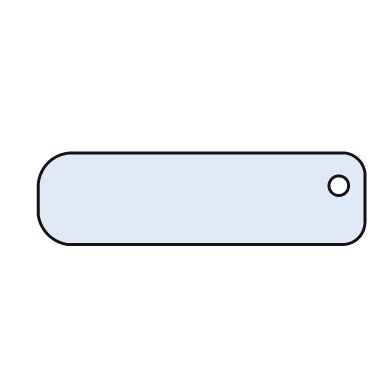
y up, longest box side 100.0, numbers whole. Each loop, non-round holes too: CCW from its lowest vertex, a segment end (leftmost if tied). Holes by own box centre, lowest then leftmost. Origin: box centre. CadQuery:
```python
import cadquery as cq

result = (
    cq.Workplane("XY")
    .moveTo(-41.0, -14.0)
    .lineTo(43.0, -14.0)
    .threePointArc((48.0, -12.0), (50.0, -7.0))
    .lineTo(50.0, 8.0)
    .threePointArc((48.0, 12.0), (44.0, 14.0))
    .lineTo(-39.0, 14.0)
    .threePointArc((-47.0, 11.0), (-50.0, 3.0))
    .lineTo(-50.0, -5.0)
    .threePointArc((-47.0, -11.0), (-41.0, -14.0))
    .close()
    .moveTo(42.0, 4.0)
    .circle(3.0)
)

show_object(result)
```